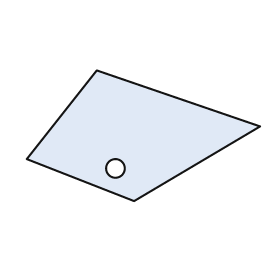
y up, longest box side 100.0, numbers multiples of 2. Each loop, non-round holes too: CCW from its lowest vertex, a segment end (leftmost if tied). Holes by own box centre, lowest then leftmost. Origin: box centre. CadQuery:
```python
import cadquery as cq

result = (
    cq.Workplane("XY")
    .moveTo(-4.0, -28.0)
    .lineTo(50.0, 4.0)
    .lineTo(-20.0, 28.0)
    .lineTo(-50.0, -10.0)
    .close()
    .moveTo(-12.0, -14.0)
    .circle(4.0)
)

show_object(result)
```